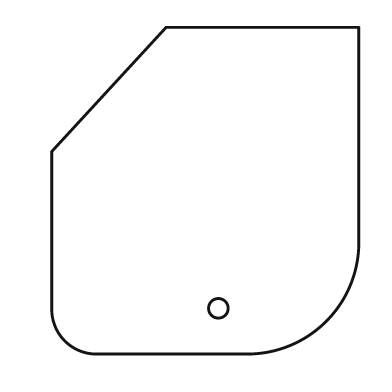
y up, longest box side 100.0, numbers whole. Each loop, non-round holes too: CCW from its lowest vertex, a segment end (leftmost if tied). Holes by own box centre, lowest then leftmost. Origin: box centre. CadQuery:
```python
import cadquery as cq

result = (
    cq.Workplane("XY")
    .moveTo(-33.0, -50.0)
    .lineTo(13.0, -50.0)
    .threePointArc((37.0, -40.0), (47.0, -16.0))
    .lineTo(47.0, 50.0)
    .lineTo(-12.0, 50.0)
    .lineTo(-47.0, 12.0)
    .lineTo(-47.0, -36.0)
    .threePointArc((-43.0, -46.0), (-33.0, -50.0))
    .close()
    .moveTo(4.0, -36.0)
    .circle(3.0)
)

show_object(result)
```